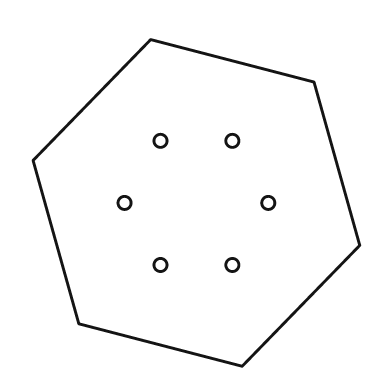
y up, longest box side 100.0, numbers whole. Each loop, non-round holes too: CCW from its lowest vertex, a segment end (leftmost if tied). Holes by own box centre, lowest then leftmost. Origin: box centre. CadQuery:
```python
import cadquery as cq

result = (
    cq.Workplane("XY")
    .moveTo(14.0, -50.0)
    .lineTo(50.0, -13.0)
    .lineTo(36.0, 37.0)
    .lineTo(-14.0, 50.0)
    .lineTo(-50.0, 13.0)
    .lineTo(-36.0, -37.0)
    .close()
    .moveTo(-11.0, -19.0)
    .circle(2.0)
    .moveTo(11.0, -19.0)
    .circle(2.0)
    .moveTo(-22.0, 0.0)
    .circle(2.0)
    .moveTo(22.0, 0.0)
    .circle(2.0)
    .moveTo(-11.0, 19.0)
    .circle(2.0)
    .moveTo(11.0, 19.0)
    .circle(2.0)
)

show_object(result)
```